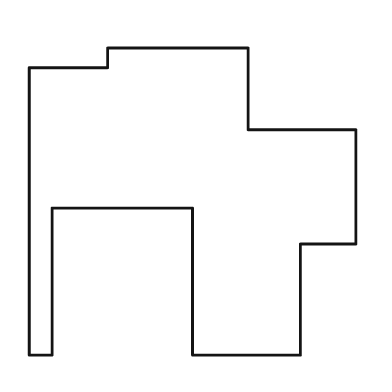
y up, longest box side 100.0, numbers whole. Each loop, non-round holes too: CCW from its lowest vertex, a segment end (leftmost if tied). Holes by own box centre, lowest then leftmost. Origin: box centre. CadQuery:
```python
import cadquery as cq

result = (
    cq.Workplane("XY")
    .moveTo(-50.0, -47.0)
    .lineTo(-43.0, -47.0)
    .lineTo(-43.0, -2.0)
    .lineTo(0.0, -2.0)
    .lineTo(0.0, -47.0)
    .lineTo(33.0, -47.0)
    .lineTo(33.0, -13.0)
    .lineTo(50.0, -13.0)
    .lineTo(50.0, 22.0)
    .lineTo(17.0, 22.0)
    .lineTo(17.0, 47.0)
    .lineTo(-26.0, 47.0)
    .lineTo(-26.0, 41.0)
    .lineTo(-50.0, 41.0)
    .close()
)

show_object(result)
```